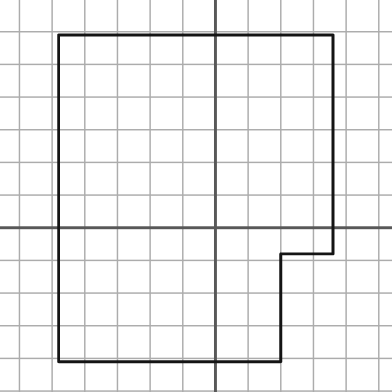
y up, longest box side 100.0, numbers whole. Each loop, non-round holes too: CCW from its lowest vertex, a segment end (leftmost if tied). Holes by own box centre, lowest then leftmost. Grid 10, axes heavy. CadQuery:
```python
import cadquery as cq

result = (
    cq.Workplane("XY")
    .moveTo(-48.0, -41.0)
    .lineTo(20.0, -41.0)
    .lineTo(20.0, -8.0)
    .lineTo(36.0, -8.0)
    .lineTo(36.0, 59.0)
    .lineTo(-48.0, 59.0)
    .close()
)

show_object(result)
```